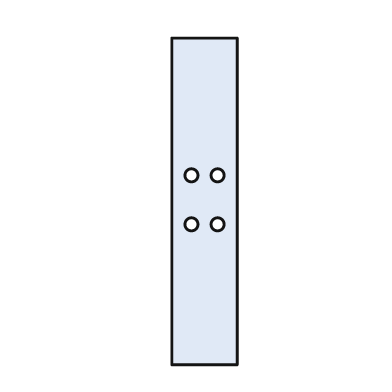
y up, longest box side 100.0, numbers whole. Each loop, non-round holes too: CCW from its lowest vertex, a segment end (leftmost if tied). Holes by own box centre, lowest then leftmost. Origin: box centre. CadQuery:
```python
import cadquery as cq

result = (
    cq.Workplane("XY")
    .moveTo(-10.0, -50.0)
    .lineTo(10.0, -50.0)
    .lineTo(10.0, 50.0)
    .lineTo(-10.0, 50.0)
    .close()
    .moveTo(-4.0, -7.0)
    .circle(2.0)
    .moveTo(4.0, -7.0)
    .circle(2.0)
    .moveTo(-4.0, 8.0)
    .circle(2.0)
    .moveTo(4.0, 8.0)
    .circle(2.0)
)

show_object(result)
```